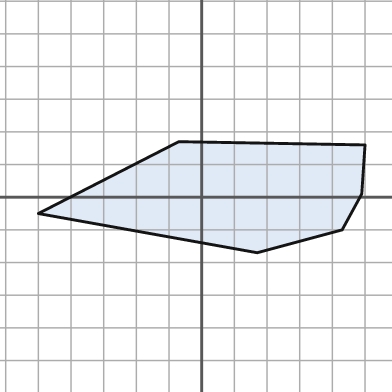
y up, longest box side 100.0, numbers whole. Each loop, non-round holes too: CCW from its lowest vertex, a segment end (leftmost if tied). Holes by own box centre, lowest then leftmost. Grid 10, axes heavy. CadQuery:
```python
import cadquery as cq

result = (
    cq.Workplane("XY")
    .moveTo(17.0, -17.0)
    .lineTo(43.0, -10.0)
    .lineTo(49.0, 1.0)
    .lineTo(50.0, 16.0)
    .lineTo(-7.0, 17.0)
    .lineTo(-50.0, -5.0)
    .close()
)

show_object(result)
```